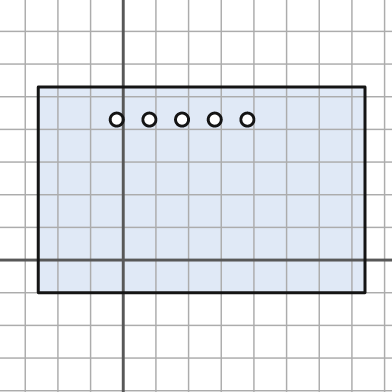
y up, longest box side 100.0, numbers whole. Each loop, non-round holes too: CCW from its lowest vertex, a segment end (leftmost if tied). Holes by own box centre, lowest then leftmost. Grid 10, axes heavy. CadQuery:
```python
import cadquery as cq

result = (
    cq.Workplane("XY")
    .moveTo(-26.0, -10.0)
    .lineTo(74.0, -10.0)
    .lineTo(74.0, 53.0)
    .lineTo(-26.0, 53.0)
    .close()
    .moveTo(-2.0, 43.0)
    .circle(2.0)
    .moveTo(8.0, 43.0)
    .circle(2.0)
    .moveTo(18.0, 43.0)
    .circle(2.0)
    .moveTo(28.0, 43.0)
    .circle(2.0)
    .moveTo(38.0, 43.0)
    .circle(2.0)
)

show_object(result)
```